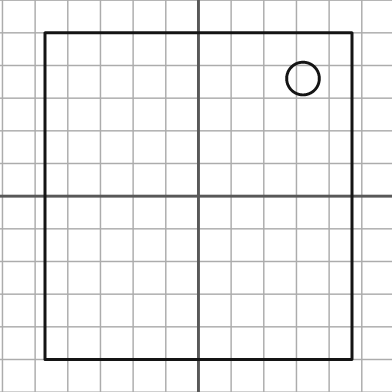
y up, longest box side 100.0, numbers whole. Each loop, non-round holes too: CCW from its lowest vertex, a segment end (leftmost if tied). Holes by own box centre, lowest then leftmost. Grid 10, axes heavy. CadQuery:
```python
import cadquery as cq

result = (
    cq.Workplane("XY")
    .moveTo(-47.0, -50.0)
    .lineTo(47.0, -50.0)
    .lineTo(47.0, 50.0)
    .lineTo(-47.0, 50.0)
    .close()
    .moveTo(32.0, 36.0)
    .circle(5.0)
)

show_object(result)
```